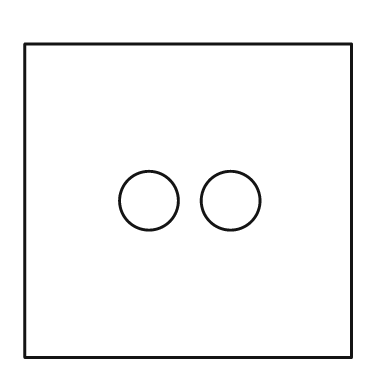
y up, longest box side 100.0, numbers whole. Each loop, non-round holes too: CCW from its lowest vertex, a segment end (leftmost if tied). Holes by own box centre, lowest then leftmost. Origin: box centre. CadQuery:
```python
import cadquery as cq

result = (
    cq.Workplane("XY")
    .moveTo(-50.0, -48.0)
    .lineTo(50.0, -48.0)
    .lineTo(50.0, 48.0)
    .lineTo(-50.0, 48.0)
    .close()
    .moveTo(-12.0, 0.0)
    .circle(9.0)
    .moveTo(13.0, 0.0)
    .circle(9.0)
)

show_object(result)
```